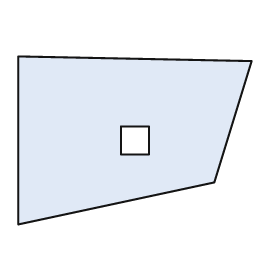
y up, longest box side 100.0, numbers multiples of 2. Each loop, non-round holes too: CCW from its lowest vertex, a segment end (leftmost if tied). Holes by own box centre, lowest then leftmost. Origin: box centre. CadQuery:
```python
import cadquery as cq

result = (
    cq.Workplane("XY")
    .moveTo(-50.0, -36.0)
    .lineTo(34.0, -18.0)
    .lineTo(50.0, 34.0)
    .lineTo(-50.0, 36.0)
    .close()
    .moveTo(-6.0, -6.0)
    .lineTo(6.0, -6.0)
    .lineTo(6.0, 6.0)
    .lineTo(-6.0, 6.0)
    .close()
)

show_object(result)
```